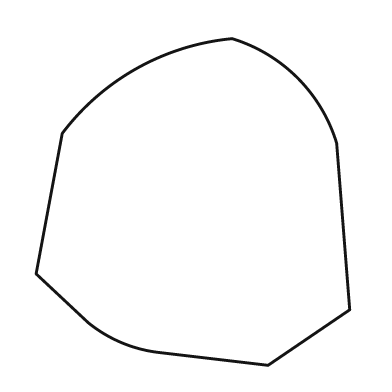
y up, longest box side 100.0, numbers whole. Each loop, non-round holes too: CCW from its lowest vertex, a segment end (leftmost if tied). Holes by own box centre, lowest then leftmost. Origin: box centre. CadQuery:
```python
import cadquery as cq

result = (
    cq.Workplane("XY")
    .moveTo(23.0, -50.0)
    .lineTo(48.0, -33.0)
    .lineTo(44.0, 18.0)
    .threePointArc((32.0, 38.0), (12.0, 50.0))
    .threePointArc((-17.0, 41.0), (-40.0, 21.0))
    .lineTo(-48.0, -22.0)
    .lineTo(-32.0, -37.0)
    .threePointArc((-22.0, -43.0), (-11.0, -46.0))
    .close()
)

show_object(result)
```